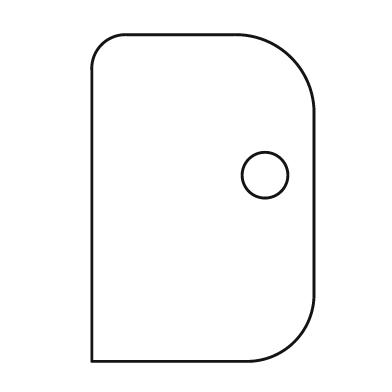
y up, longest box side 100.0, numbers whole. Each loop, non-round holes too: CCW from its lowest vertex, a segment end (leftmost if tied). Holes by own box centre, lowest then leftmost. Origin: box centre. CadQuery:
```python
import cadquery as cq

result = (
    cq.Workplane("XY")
    .moveTo(-34.0, -50.0)
    .lineTo(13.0, -50.0)
    .threePointArc((28.0, -44.0), (34.0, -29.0))
    .lineTo(34.0, 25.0)
    .threePointArc((27.0, 43.0), (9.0, 50.0))
    .lineTo(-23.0, 50.0)
    .threePointArc((-31.0, 47.0), (-34.0, 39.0))
    .close()
    .moveTo(19.0, 7.0)
    .circle(7.0)
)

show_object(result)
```